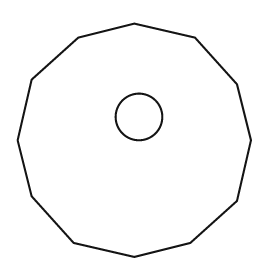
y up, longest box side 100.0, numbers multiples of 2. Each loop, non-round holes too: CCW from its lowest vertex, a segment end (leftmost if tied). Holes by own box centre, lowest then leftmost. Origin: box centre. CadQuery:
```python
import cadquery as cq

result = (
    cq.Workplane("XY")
    .moveTo(0.0, -50.0)
    .lineTo(24.0, -44.0)
    .lineTo(44.0, -26.0)
    .lineTo(50.0, 0.0)
    .lineTo(44.0, 24.0)
    .lineTo(26.0, 44.0)
    .lineTo(0.0, 50.0)
    .lineTo(-24.0, 44.0)
    .lineTo(-44.0, 26.0)
    .lineTo(-50.0, 0.0)
    .lineTo(-44.0, -24.0)
    .lineTo(-26.0, -44.0)
    .close()
    .moveTo(2.0, 10.0)
    .circle(10.0)
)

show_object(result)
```